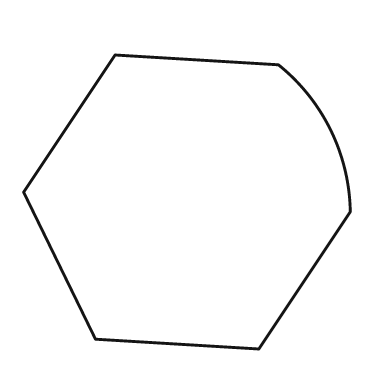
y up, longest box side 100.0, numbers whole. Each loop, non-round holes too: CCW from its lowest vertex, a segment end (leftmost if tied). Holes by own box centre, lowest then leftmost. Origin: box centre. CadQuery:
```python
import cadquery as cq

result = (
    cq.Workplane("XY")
    .moveTo(22.0, -45.0)
    .lineTo(50.0, -3.0)
    .threePointArc((44.0, 22.0), (28.0, 42.0))
    .lineTo(-22.0, 45.0)
    .lineTo(-50.0, 3.0)
    .lineTo(-28.0, -42.0)
    .close()
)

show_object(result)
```